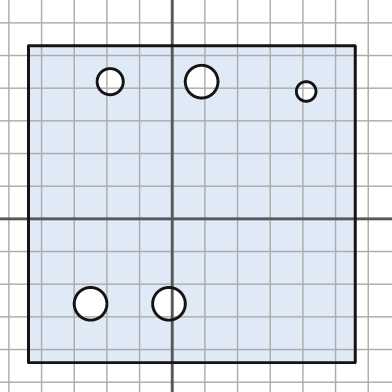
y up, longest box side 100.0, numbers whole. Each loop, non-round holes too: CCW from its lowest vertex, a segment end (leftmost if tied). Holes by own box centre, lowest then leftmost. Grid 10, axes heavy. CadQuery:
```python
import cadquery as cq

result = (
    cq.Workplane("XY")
    .moveTo(-44.0, -44.0)
    .lineTo(56.0, -44.0)
    .lineTo(56.0, 53.0)
    .lineTo(-44.0, 53.0)
    .close()
    .moveTo(-25.0, -26.0)
    .circle(5.0)
    .moveTo(-1.0, -26.0)
    .circle(5.0)
    .moveTo(41.0, 39.0)
    .circle(3.0)
    .moveTo(-19.0, 42.0)
    .circle(4.0)
    .moveTo(9.0, 42.0)
    .circle(5.0)
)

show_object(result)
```